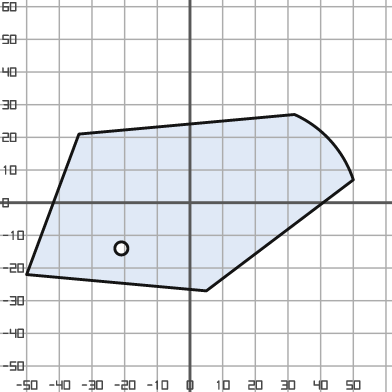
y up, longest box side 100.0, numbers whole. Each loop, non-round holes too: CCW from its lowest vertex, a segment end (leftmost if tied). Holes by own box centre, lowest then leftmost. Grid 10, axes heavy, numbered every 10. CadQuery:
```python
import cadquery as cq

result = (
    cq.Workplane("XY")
    .moveTo(5.0, -27.0)
    .lineTo(50.0, 7.0)
    .threePointArc((43.0, 19.0), (32.0, 27.0))
    .lineTo(-34.0, 21.0)
    .lineTo(-50.0, -22.0)
    .close()
    .moveTo(-21.0, -14.0)
    .circle(2.0)
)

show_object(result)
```